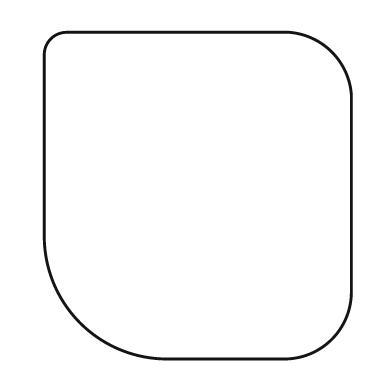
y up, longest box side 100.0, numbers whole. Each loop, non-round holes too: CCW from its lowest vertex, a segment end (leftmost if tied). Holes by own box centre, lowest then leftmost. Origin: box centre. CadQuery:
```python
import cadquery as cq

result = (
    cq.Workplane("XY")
    .moveTo(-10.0, -50.0)
    .lineTo(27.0, -50.0)
    .threePointArc((41.0, -44.0), (47.0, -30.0))
    .lineTo(47.0, 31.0)
    .threePointArc((41.0, 44.0), (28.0, 50.0))
    .lineTo(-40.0, 50.0)
    .threePointArc((-45.0, 48.0), (-47.0, 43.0))
    .lineTo(-47.0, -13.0)
    .threePointArc((-36.0, -39.0), (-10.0, -50.0))
    .close()
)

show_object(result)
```